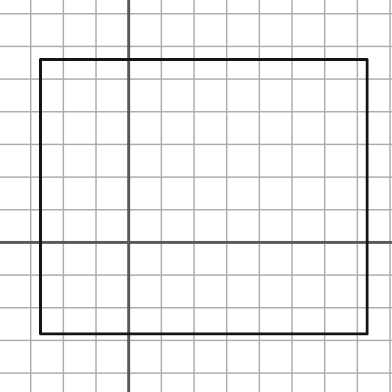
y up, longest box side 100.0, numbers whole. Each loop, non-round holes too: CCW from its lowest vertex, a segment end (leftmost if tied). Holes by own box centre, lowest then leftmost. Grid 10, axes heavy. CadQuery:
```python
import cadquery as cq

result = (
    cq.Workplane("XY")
    .moveTo(-27.0, -28.0)
    .lineTo(73.0, -28.0)
    .lineTo(73.0, 56.0)
    .lineTo(-27.0, 56.0)
    .close()
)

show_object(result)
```